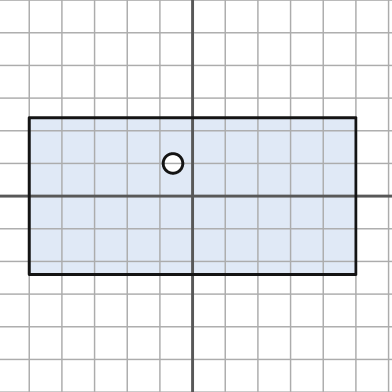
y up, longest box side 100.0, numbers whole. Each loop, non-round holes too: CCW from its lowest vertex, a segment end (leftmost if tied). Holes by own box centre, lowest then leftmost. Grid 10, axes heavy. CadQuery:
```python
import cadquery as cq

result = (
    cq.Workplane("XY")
    .moveTo(-50.0, -24.0)
    .lineTo(50.0, -24.0)
    .lineTo(50.0, 24.0)
    .lineTo(-50.0, 24.0)
    .close()
    .moveTo(-6.0, 10.0)
    .circle(3.0)
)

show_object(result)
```